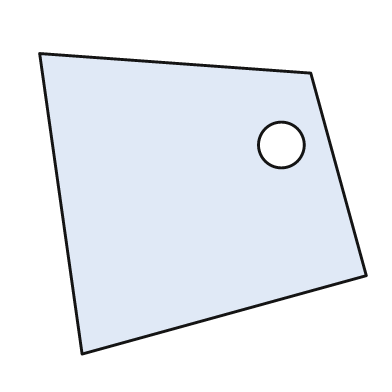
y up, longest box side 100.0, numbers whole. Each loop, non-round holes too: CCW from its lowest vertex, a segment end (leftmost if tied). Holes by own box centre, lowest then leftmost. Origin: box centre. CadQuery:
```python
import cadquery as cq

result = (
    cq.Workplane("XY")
    .moveTo(-37.0, -46.0)
    .lineTo(50.0, -22.0)
    .lineTo(33.0, 40.0)
    .lineTo(-50.0, 46.0)
    .close()
    .moveTo(24.0, 18.0)
    .circle(7.0)
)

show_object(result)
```